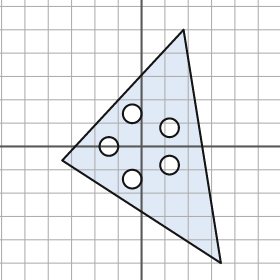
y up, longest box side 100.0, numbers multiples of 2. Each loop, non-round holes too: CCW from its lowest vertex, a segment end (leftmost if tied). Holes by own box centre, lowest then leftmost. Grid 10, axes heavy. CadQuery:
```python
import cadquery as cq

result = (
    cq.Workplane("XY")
    .moveTo(34.0, -50.0)
    .lineTo(18.0, 50.0)
    .lineTo(-34.0, -6.0)
    .close()
    .moveTo(-4.0, -14.0)
    .circle(4.0)
    .moveTo(12.0, -8.0)
    .circle(4.0)
    .moveTo(-14.0, 0.0)
    .circle(4.0)
    .moveTo(12.0, 8.0)
    .circle(4.0)
    .moveTo(-4.0, 14.0)
    .circle(4.0)
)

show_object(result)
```